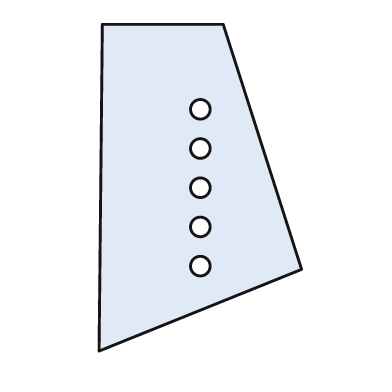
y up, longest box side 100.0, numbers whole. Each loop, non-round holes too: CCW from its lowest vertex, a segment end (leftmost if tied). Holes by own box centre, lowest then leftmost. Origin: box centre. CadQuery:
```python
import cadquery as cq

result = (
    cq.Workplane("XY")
    .moveTo(-31.0, -50.0)
    .lineTo(31.0, -25.0)
    .lineTo(7.0, 50.0)
    .lineTo(-30.0, 50.0)
    .close()
    .moveTo(0.0, -24.0)
    .circle(3.0)
    .moveTo(0.0, -12.0)
    .circle(3.0)
    .moveTo(0.0, 0.0)
    .circle(3.0)
    .moveTo(0.0, 12.0)
    .circle(3.0)
    .moveTo(0.0, 24.0)
    .circle(3.0)
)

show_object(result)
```